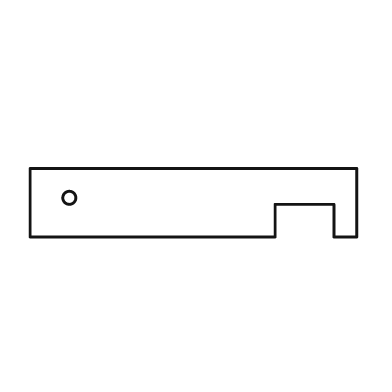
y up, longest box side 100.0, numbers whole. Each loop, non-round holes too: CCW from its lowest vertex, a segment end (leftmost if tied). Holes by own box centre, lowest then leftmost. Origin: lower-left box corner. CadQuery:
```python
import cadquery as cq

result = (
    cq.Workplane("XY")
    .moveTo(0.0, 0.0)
    .lineTo(75.0, 0.0)
    .lineTo(75.0, 10.0)
    .lineTo(93.0, 10.0)
    .lineTo(93.0, 0.0)
    .lineTo(100.0, 0.0)
    .lineTo(100.0, 21.0)
    .lineTo(0.0, 21.0)
    .close()
    .moveTo(12.0, 12.0)
    .circle(2.0)
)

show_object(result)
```